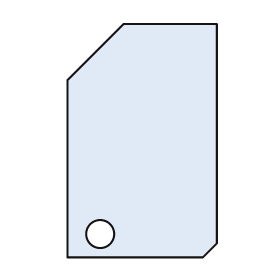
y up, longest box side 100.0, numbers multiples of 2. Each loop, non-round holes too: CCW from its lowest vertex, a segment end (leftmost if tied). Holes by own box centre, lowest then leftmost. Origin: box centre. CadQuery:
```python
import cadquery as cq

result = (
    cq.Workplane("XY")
    .moveTo(-32.0, -50.0)
    .lineTo(26.0, -50.0)
    .lineTo(32.0, -44.0)
    .lineTo(32.0, 50.0)
    .lineTo(-8.0, 50.0)
    .lineTo(-32.0, 26.0)
    .close()
    .moveTo(-18.0, -40.0)
    .circle(6.0)
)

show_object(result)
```